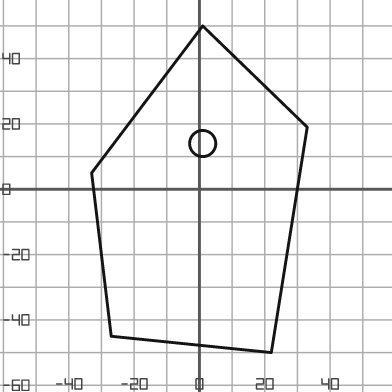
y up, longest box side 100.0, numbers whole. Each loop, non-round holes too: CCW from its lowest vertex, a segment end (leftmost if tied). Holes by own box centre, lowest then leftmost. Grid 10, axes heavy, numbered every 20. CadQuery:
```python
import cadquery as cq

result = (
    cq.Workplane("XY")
    .moveTo(22.0, -50.0)
    .lineTo(33.0, 19.0)
    .lineTo(1.0, 50.0)
    .lineTo(-33.0, 5.0)
    .lineTo(-27.0, -45.0)
    .close()
    .moveTo(1.0, 14.0)
    .circle(4.0)
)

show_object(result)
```